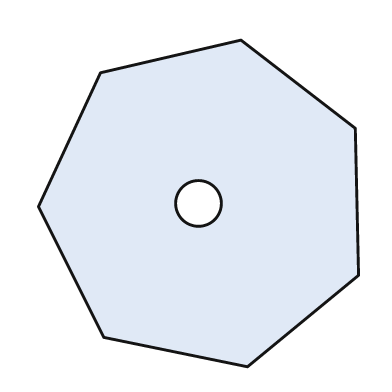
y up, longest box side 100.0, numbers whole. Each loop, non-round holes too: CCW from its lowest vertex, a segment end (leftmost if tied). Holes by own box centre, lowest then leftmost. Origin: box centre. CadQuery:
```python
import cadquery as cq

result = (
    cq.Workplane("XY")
    .moveTo(15.0, -50.0)
    .lineTo(49.0, -22.0)
    .lineTo(48.0, 23.0)
    .lineTo(13.0, 50.0)
    .lineTo(-30.0, 40.0)
    .lineTo(-49.0, -1.0)
    .lineTo(-29.0, -41.0)
    .close()
    .moveTo(0.0, 0.0)
    .circle(7.0)
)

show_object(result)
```